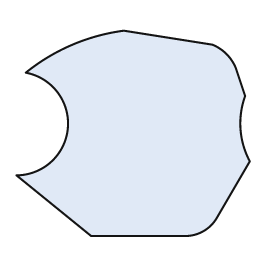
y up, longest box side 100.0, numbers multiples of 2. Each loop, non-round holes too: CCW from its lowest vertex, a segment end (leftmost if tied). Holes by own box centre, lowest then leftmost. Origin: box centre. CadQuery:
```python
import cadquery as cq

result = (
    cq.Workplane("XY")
    .moveTo(-18.0, -44.0)
    .lineTo(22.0, -44.0)
    .threePointArc((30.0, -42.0), (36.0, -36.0))
    .lineTo(50.0, -12.0)
    .threePointArc((46.0, 2.0), (48.0, 16.0))
    .lineTo(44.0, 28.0)
    .threePointArc((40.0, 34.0), (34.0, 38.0))
    .lineTo(-4.0, 44.0)
    .threePointArc((-26.0, 38.0), (-46.0, 26.0))
    .threePointArc((-28.0, 2.0), (-50.0, -18.0))
    .close()
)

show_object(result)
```